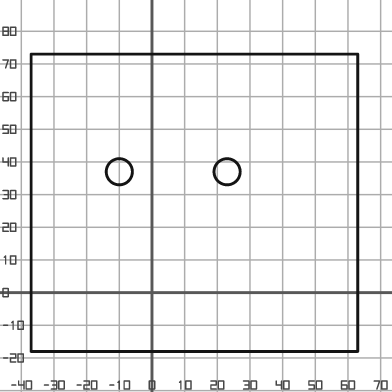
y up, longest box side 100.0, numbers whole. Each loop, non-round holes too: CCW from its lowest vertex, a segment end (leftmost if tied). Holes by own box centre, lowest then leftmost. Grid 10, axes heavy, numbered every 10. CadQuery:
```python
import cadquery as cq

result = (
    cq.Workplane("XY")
    .moveTo(-37.0, -18.0)
    .lineTo(63.0, -18.0)
    .lineTo(63.0, 73.0)
    .lineTo(-37.0, 73.0)
    .close()
    .moveTo(-10.0, 37.0)
    .circle(4.0)
    .moveTo(23.0, 37.0)
    .circle(4.0)
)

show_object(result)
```